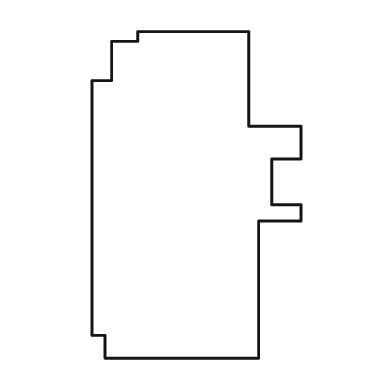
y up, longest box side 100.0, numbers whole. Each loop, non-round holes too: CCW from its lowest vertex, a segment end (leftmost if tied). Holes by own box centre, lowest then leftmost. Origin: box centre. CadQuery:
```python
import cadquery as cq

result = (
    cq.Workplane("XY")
    .moveTo(-28.0, -50.0)
    .lineTo(19.0, -50.0)
    .lineTo(19.0, -8.0)
    .lineTo(32.0, -8.0)
    .lineTo(32.0, -3.0)
    .lineTo(23.0, -3.0)
    .lineTo(23.0, 11.0)
    .lineTo(32.0, 11.0)
    .lineTo(32.0, 21.0)
    .lineTo(16.0, 21.0)
    .lineTo(16.0, 50.0)
    .lineTo(-18.0, 50.0)
    .lineTo(-18.0, 47.0)
    .lineTo(-26.0, 47.0)
    .lineTo(-26.0, 35.0)
    .lineTo(-32.0, 35.0)
    .lineTo(-32.0, -43.0)
    .lineTo(-28.0, -43.0)
    .close()
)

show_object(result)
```